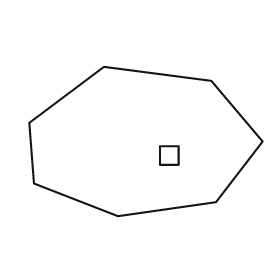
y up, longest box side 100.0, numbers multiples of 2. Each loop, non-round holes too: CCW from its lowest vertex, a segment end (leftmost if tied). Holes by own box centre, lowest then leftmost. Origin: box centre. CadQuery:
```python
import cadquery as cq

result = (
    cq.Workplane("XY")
    .moveTo(-12.0, -32.0)
    .lineTo(30.0, -26.0)
    .lineTo(50.0, 0.0)
    .lineTo(28.0, 26.0)
    .lineTo(-18.0, 32.0)
    .lineTo(-50.0, 8.0)
    .lineTo(-48.0, -18.0)
    .close()
    .moveTo(6.0, -10.0)
    .lineTo(14.0, -10.0)
    .lineTo(14.0, -2.0)
    .lineTo(6.0, -2.0)
    .close()
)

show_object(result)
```